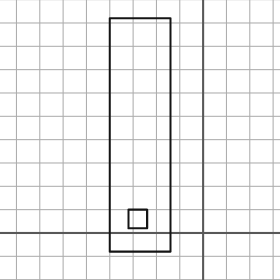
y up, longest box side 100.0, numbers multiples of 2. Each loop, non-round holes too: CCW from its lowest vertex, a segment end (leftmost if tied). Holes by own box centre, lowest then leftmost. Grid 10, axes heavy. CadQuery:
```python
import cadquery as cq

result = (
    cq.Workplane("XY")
    .moveTo(-40.0, -8.0)
    .lineTo(-14.0, -8.0)
    .lineTo(-14.0, 92.0)
    .lineTo(-40.0, 92.0)
    .close()
    .moveTo(-32.0, 2.0)
    .lineTo(-24.0, 2.0)
    .lineTo(-24.0, 10.0)
    .lineTo(-32.0, 10.0)
    .close()
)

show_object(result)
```